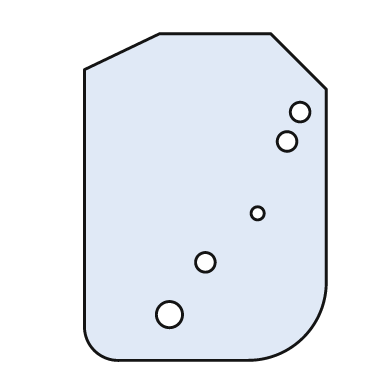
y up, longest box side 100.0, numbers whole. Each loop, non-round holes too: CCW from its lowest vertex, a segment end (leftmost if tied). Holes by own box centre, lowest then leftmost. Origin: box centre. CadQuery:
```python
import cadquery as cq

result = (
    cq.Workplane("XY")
    .moveTo(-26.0, -50.0)
    .lineTo(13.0, -50.0)
    .threePointArc((30.0, -43.0), (37.0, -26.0))
    .lineTo(37.0, 33.0)
    .lineTo(20.0, 50.0)
    .lineTo(-14.0, 50.0)
    .lineTo(-37.0, 39.0)
    .lineTo(-37.0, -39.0)
    .threePointArc((-34.0, -47.0), (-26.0, -50.0))
    .close()
    .moveTo(-11.0, -36.0)
    .circle(4.0)
    .moveTo(0.0, -20.0)
    .circle(3.0)
    .moveTo(16.0, -5.0)
    .circle(2.0)
    .moveTo(25.0, 17.0)
    .circle(3.0)
    .moveTo(29.0, 26.0)
    .circle(3.0)
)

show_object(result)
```